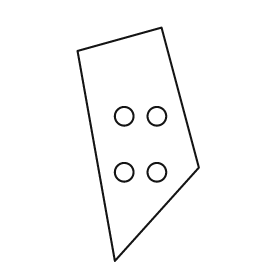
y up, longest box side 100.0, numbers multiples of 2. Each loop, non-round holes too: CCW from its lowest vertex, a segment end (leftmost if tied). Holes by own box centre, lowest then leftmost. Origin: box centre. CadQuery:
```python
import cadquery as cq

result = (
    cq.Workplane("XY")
    .moveTo(-10.0, -50.0)
    .lineTo(26.0, -10.0)
    .lineTo(10.0, 50.0)
    .lineTo(-26.0, 40.0)
    .close()
    .moveTo(-6.0, -12.0)
    .circle(4.0)
    .moveTo(8.0, -12.0)
    .circle(4.0)
    .moveTo(-6.0, 12.0)
    .circle(4.0)
    .moveTo(8.0, 12.0)
    .circle(4.0)
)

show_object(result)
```